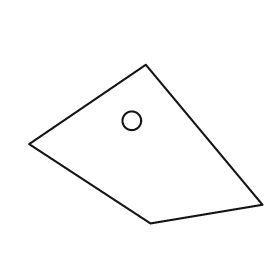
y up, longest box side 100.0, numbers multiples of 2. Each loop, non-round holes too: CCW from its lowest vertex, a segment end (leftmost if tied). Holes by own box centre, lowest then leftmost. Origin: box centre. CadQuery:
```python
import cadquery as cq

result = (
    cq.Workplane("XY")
    .moveTo(2.0, -34.0)
    .lineTo(50.0, -26.0)
    .lineTo(0.0, 34.0)
    .lineTo(-50.0, 0.0)
    .close()
    .moveTo(-6.0, 10.0)
    .circle(4.0)
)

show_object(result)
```